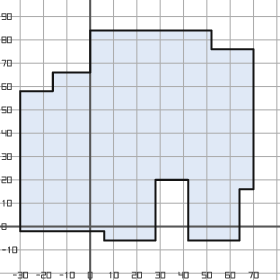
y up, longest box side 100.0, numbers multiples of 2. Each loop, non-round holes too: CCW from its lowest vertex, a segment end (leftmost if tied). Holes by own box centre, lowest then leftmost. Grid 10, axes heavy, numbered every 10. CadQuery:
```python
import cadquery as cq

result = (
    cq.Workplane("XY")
    .moveTo(6.0, -6.0)
    .lineTo(28.0, -6.0)
    .lineTo(28.0, 20.0)
    .lineTo(42.0, 20.0)
    .lineTo(42.0, -6.0)
    .lineTo(64.0, -6.0)
    .lineTo(64.0, 16.0)
    .lineTo(70.0, 16.0)
    .lineTo(70.0, 76.0)
    .lineTo(52.0, 76.0)
    .lineTo(52.0, 84.0)
    .lineTo(0.0, 84.0)
    .lineTo(0.0, 66.0)
    .lineTo(-16.0, 66.0)
    .lineTo(-16.0, 58.0)
    .lineTo(-30.0, 58.0)
    .lineTo(-30.0, -2.0)
    .lineTo(6.0, -2.0)
    .close()
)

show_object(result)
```